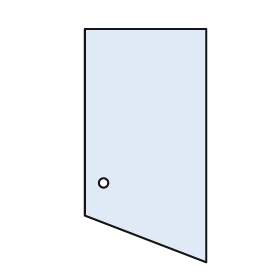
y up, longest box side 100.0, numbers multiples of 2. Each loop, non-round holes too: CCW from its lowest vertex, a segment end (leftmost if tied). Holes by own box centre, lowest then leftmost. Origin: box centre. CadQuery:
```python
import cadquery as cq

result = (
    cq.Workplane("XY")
    .moveTo(26.0, -50.0)
    .lineTo(26.0, 50.0)
    .lineTo(-26.0, 50.0)
    .lineTo(-26.0, -30.0)
    .close()
    .moveTo(-18.0, -16.0)
    .circle(2.0)
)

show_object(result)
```